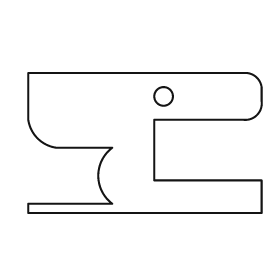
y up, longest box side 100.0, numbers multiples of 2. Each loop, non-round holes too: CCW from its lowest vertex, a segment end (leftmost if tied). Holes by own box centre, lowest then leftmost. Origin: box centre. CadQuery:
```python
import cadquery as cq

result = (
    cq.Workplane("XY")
    .moveTo(-50.0, -30.0)
    .lineTo(50.0, -30.0)
    .lineTo(50.0, -16.0)
    .lineTo(4.0, -16.0)
    .lineTo(4.0, 10.0)
    .lineTo(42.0, 10.0)
    .threePointArc((48.0, 12.0), (50.0, 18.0))
    .lineTo(50.0, 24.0)
    .threePointArc((48.0, 28.0), (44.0, 30.0))
    .lineTo(-50.0, 30.0)
    .lineTo(-50.0, 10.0)
    .threePointArc((-46.0, 2.0), (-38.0, -2.0))
    .lineTo(-14.0, -2.0)
    .threePointArc((-20.0, -14.0), (-14.0, -26.0))
    .lineTo(-50.0, -26.0)
    .close()
    .moveTo(8.0, 20.0)
    .circle(4.0)
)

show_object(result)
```